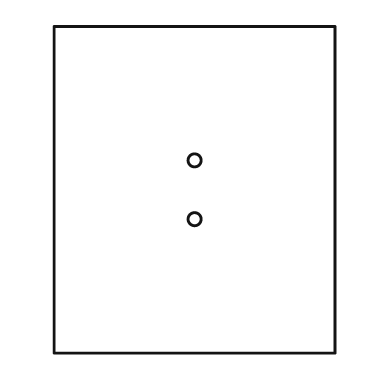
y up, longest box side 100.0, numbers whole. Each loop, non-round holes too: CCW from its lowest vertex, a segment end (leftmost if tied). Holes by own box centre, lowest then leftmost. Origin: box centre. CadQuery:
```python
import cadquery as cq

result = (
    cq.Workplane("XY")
    .moveTo(-43.0, -50.0)
    .lineTo(43.0, -50.0)
    .lineTo(43.0, 50.0)
    .lineTo(-43.0, 50.0)
    .close()
    .moveTo(0.0, -9.0)
    .circle(2.0)
    .moveTo(0.0, 9.0)
    .circle(2.0)
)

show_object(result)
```